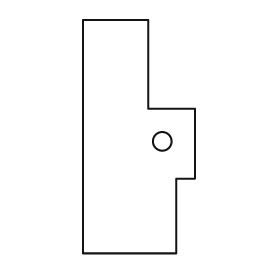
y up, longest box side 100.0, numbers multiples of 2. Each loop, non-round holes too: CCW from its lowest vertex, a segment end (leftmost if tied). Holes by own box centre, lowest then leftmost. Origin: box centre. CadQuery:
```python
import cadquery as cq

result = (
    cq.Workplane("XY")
    .moveTo(-24.0, -50.0)
    .lineTo(16.0, -50.0)
    .lineTo(16.0, -18.0)
    .lineTo(24.0, -18.0)
    .lineTo(24.0, 12.0)
    .lineTo(4.0, 12.0)
    .lineTo(4.0, 50.0)
    .lineTo(-24.0, 50.0)
    .close()
    .moveTo(10.0, -2.0)
    .circle(4.0)
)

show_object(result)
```